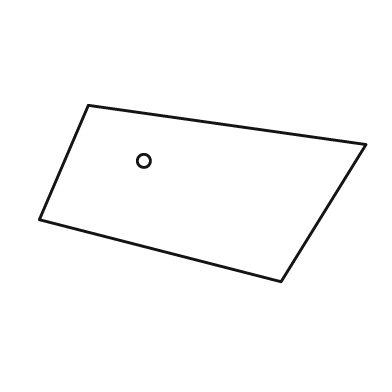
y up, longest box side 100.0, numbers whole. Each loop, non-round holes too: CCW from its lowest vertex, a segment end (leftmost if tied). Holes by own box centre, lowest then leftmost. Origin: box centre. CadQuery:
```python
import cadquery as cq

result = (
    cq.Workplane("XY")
    .moveTo(24.0, -27.0)
    .lineTo(50.0, 15.0)
    .lineTo(-35.0, 27.0)
    .lineTo(-50.0, -8.0)
    .close()
    .moveTo(-18.0, 10.0)
    .circle(2.0)
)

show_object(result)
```